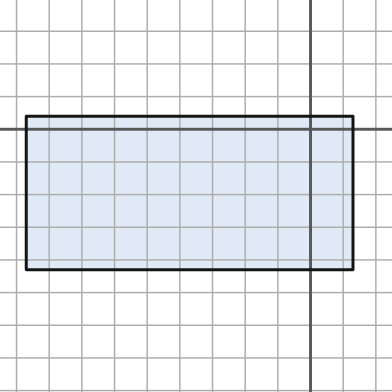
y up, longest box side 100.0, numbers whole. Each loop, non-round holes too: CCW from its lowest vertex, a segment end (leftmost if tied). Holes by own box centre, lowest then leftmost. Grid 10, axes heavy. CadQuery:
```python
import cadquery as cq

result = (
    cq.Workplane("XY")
    .moveTo(-87.0, -43.0)
    .lineTo(13.0, -43.0)
    .lineTo(13.0, 4.0)
    .lineTo(-87.0, 4.0)
    .close()
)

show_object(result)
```